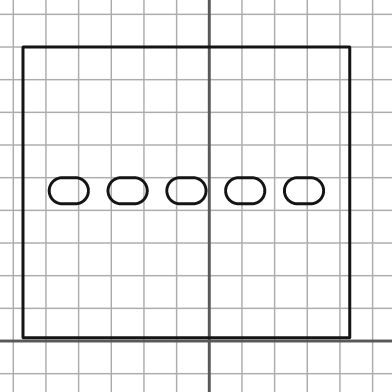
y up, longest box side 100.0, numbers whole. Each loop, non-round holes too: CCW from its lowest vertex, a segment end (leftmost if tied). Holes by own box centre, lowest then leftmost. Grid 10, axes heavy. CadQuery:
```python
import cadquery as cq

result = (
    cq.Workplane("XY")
    .moveTo(-57.0, 1.0)
    .lineTo(43.0, 1.0)
    .lineTo(43.0, 90.0)
    .lineTo(-57.0, 90.0)
    .close()
    .moveTo(-45.0, 42.0)
    .lineTo(-41.0, 42.0)
    .threePointArc((-37.0, 46.0), (-41.0, 50.0))
    .lineTo(-45.0, 50.0)
    .threePointArc((-49.0, 46.0), (-45.0, 42.0))
    .close()
    .moveTo(-27.0, 42.0)
    .lineTo(-23.0, 42.0)
    .threePointArc((-19.0, 46.0), (-23.0, 50.0))
    .lineTo(-27.0, 50.0)
    .threePointArc((-31.0, 46.0), (-27.0, 42.0))
    .close()
    .moveTo(-9.0, 42.0)
    .lineTo(-5.0, 42.0)
    .threePointArc((-1.0, 46.0), (-5.0, 50.0))
    .lineTo(-9.0, 50.0)
    .threePointArc((-13.0, 46.0), (-9.0, 42.0))
    .close()
    .moveTo(9.0, 42.0)
    .lineTo(13.0, 42.0)
    .threePointArc((17.0, 46.0), (13.0, 50.0))
    .lineTo(9.0, 50.0)
    .threePointArc((5.0, 46.0), (9.0, 42.0))
    .close()
    .moveTo(27.0, 42.0)
    .lineTo(31.0, 42.0)
    .threePointArc((35.0, 46.0), (31.0, 50.0))
    .lineTo(27.0, 50.0)
    .threePointArc((23.0, 46.0), (27.0, 42.0))
    .close()
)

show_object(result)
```